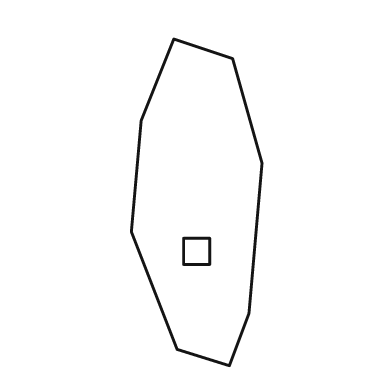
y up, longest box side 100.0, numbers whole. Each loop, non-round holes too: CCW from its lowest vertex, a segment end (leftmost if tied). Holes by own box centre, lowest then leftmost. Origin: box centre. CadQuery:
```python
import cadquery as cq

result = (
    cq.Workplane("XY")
    .moveTo(10.0, -50.0)
    .lineTo(16.0, -34.0)
    .lineTo(20.0, 12.0)
    .lineTo(11.0, 44.0)
    .lineTo(-7.0, 50.0)
    .lineTo(-17.0, 25.0)
    .lineTo(-20.0, -9.0)
    .lineTo(-6.0, -45.0)
    .close()
    .moveTo(-4.0, -19.0)
    .lineTo(4.0, -19.0)
    .lineTo(4.0, -11.0)
    .lineTo(-4.0, -11.0)
    .close()
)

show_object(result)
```